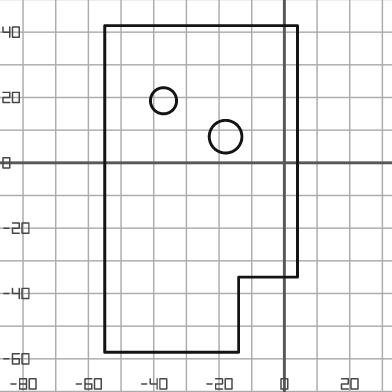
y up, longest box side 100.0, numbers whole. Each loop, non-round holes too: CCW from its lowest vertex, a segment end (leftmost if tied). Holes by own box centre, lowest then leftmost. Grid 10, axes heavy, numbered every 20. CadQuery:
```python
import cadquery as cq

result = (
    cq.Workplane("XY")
    .moveTo(-55.0, -58.0)
    .lineTo(-14.0, -58.0)
    .lineTo(-14.0, -35.0)
    .lineTo(4.0, -35.0)
    .lineTo(4.0, 42.0)
    .lineTo(-55.0, 42.0)
    .close()
    .moveTo(-18.0, 8.0)
    .circle(5.0)
    .moveTo(-37.0, 19.0)
    .circle(4.0)
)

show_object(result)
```